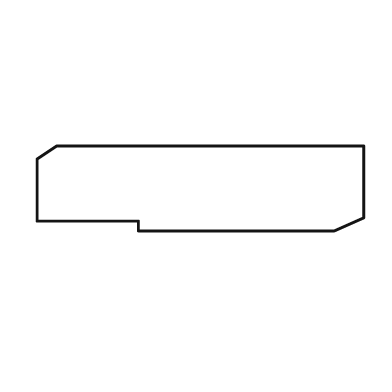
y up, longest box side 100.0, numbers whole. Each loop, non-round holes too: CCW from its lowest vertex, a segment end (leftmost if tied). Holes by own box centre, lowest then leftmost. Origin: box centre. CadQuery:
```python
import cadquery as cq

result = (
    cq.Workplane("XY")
    .moveTo(-19.0, -13.0)
    .lineTo(41.0, -13.0)
    .lineTo(50.0, -9.0)
    .lineTo(50.0, 13.0)
    .lineTo(-44.0, 13.0)
    .lineTo(-50.0, 9.0)
    .lineTo(-50.0, -10.0)
    .lineTo(-19.0, -10.0)
    .close()
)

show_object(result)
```